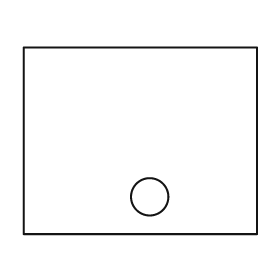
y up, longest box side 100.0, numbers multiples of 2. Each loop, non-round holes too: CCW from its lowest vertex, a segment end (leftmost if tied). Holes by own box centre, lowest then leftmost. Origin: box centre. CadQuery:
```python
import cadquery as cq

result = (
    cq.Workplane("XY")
    .moveTo(-50.0, -40.0)
    .lineTo(50.0, -40.0)
    .lineTo(50.0, 40.0)
    .lineTo(-50.0, 40.0)
    .close()
    .moveTo(4.0, -24.0)
    .circle(8.0)
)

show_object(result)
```